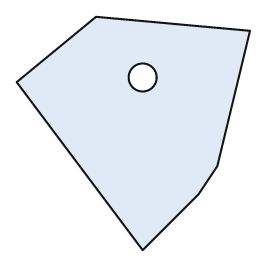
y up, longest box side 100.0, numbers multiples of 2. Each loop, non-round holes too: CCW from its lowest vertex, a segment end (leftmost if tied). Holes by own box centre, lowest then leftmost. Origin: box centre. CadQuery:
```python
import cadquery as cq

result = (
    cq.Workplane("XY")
    .moveTo(4.0, -50.0)
    .lineTo(28.0, -26.0)
    .lineTo(36.0, -14.0)
    .lineTo(50.0, 44.0)
    .lineTo(-16.0, 50.0)
    .lineTo(-50.0, 22.0)
    .close()
    .moveTo(4.0, 24.0)
    .circle(6.0)
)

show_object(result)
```